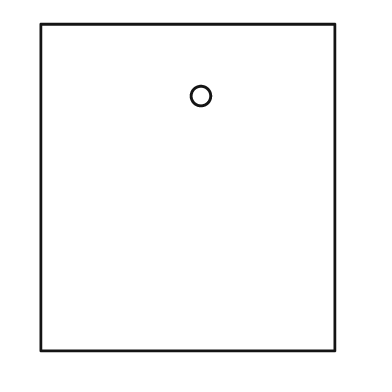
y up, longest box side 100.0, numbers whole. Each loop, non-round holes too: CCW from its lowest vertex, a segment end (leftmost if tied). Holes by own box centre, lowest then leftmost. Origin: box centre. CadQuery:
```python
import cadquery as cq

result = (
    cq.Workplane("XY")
    .moveTo(-45.0, -50.0)
    .lineTo(45.0, -50.0)
    .lineTo(45.0, 50.0)
    .lineTo(-45.0, 50.0)
    .close()
    .moveTo(4.0, 28.0)
    .circle(3.0)
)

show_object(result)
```